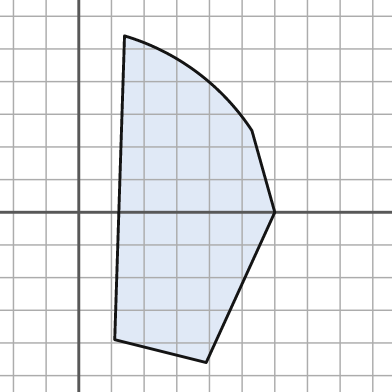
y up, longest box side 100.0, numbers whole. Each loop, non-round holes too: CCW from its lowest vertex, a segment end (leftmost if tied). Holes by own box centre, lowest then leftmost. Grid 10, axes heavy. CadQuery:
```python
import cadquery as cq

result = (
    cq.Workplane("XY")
    .moveTo(39.0, -46.0)
    .lineTo(60.0, 0.0)
    .lineTo(53.0, 25.0)
    .threePointArc((36.0, 43.0), (14.0, 54.0))
    .lineTo(11.0, -39.0)
    .close()
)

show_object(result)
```